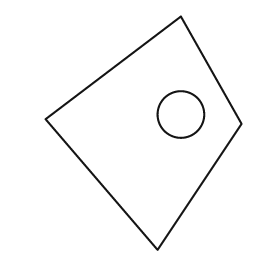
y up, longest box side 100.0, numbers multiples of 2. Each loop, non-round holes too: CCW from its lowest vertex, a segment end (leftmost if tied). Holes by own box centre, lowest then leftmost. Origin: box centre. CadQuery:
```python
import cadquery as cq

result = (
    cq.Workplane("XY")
    .moveTo(6.0, -50.0)
    .lineTo(42.0, 4.0)
    .lineTo(16.0, 50.0)
    .lineTo(-42.0, 6.0)
    .close()
    .moveTo(16.0, 8.0)
    .circle(10.0)
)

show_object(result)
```